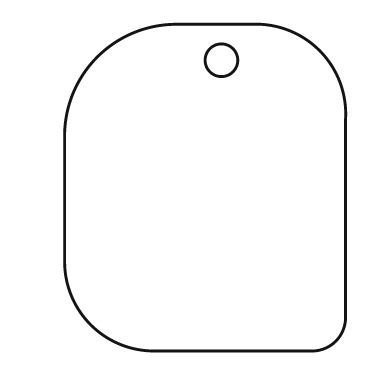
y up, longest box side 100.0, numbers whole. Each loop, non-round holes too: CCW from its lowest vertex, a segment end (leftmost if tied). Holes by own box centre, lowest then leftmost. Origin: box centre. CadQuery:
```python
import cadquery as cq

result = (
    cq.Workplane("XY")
    .moveTo(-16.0, -50.0)
    .lineTo(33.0, -50.0)
    .threePointArc((40.0, -47.0), (43.0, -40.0))
    .lineTo(43.0, 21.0)
    .threePointArc((35.0, 42.0), (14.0, 50.0))
    .lineTo(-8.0, 50.0)
    .threePointArc((-33.0, 40.0), (-43.0, 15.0))
    .lineTo(-43.0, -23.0)
    .threePointArc((-35.0, -42.0), (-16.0, -50.0))
    .close()
    .moveTo(5.0, 39.0)
    .circle(5.0)
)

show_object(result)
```